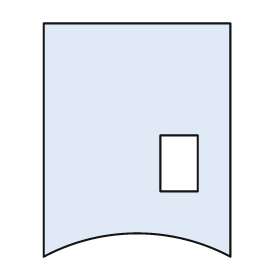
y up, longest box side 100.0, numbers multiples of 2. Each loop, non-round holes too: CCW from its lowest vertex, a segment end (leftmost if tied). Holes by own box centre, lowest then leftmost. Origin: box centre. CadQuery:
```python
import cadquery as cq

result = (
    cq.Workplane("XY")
    .moveTo(-40.0, -50.0)
    .threePointArc((0.0, -40.0), (40.0, -50.0))
    .lineTo(40.0, 50.0)
    .lineTo(-40.0, 50.0)
    .close()
    .moveTo(10.0, -22.0)
    .lineTo(26.0, -22.0)
    .lineTo(26.0, 2.0)
    .lineTo(10.0, 2.0)
    .close()
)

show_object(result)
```